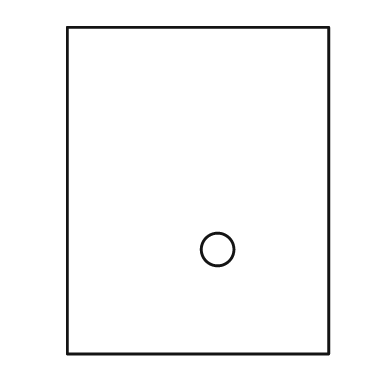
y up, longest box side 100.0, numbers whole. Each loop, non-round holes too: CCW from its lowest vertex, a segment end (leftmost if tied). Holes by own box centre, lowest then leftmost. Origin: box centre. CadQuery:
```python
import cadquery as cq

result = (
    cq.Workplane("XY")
    .moveTo(-40.0, -50.0)
    .lineTo(40.0, -50.0)
    .lineTo(40.0, 50.0)
    .lineTo(-40.0, 50.0)
    .close()
    .moveTo(6.0, -18.0)
    .circle(5.0)
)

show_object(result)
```